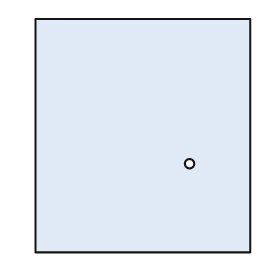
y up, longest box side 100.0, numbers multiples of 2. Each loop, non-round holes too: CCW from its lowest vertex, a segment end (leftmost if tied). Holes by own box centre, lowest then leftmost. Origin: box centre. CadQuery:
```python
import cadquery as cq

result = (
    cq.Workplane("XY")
    .moveTo(-46.0, -50.0)
    .lineTo(46.0, -50.0)
    .lineTo(46.0, 50.0)
    .lineTo(-46.0, 50.0)
    .close()
    .moveTo(20.0, -12.0)
    .circle(2.0)
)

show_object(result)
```